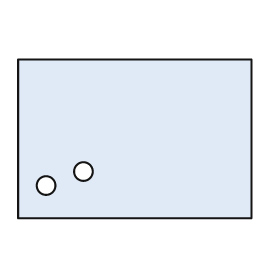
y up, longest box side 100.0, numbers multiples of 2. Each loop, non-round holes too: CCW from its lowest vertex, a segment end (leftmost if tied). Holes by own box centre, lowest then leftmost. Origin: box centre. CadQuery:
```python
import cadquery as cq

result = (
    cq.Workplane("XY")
    .moveTo(-50.0, -34.0)
    .lineTo(50.0, -34.0)
    .lineTo(50.0, 34.0)
    .lineTo(-50.0, 34.0)
    .close()
    .moveTo(-38.0, -20.0)
    .circle(4.0)
    .moveTo(-22.0, -14.0)
    .circle(4.0)
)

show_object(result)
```